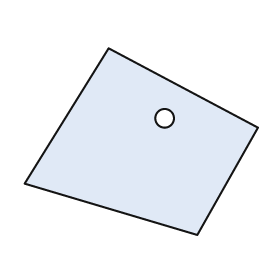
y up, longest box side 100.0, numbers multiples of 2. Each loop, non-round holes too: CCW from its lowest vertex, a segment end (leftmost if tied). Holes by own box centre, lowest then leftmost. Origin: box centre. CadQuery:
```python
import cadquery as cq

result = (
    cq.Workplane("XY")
    .moveTo(24.0, -40.0)
    .lineTo(50.0, 6.0)
    .lineTo(-14.0, 40.0)
    .lineTo(-50.0, -18.0)
    .close()
    .moveTo(10.0, 10.0)
    .circle(4.0)
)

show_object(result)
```